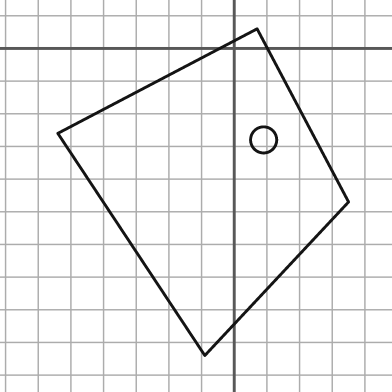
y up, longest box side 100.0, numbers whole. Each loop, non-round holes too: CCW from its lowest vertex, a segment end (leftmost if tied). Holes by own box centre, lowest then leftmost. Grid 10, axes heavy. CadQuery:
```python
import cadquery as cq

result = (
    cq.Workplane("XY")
    .moveTo(-9.0, -94.0)
    .lineTo(35.0, -47.0)
    .lineTo(7.0, 6.0)
    .lineTo(-54.0, -26.0)
    .close()
    .moveTo(9.0, -28.0)
    .circle(4.0)
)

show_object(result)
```